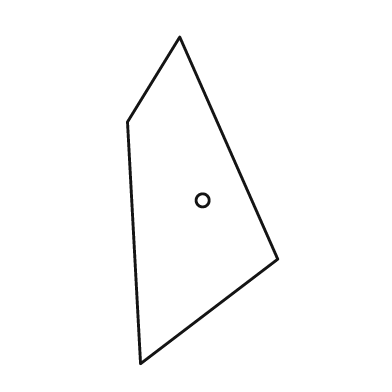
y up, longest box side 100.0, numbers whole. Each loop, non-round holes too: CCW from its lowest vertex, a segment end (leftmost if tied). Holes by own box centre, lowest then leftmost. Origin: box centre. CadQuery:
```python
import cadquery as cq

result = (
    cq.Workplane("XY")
    .moveTo(-19.0, -50.0)
    .lineTo(23.0, -18.0)
    .lineTo(-7.0, 50.0)
    .lineTo(-23.0, 24.0)
    .close()
    .moveTo(0.0, 0.0)
    .circle(2.0)
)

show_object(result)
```